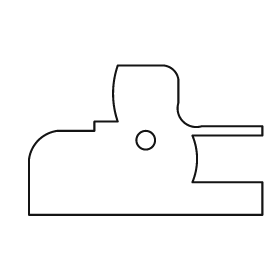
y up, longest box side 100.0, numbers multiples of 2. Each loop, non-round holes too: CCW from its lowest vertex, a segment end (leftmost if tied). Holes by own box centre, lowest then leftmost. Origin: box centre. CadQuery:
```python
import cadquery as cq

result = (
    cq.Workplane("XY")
    .moveTo(-50.0, -32.0)
    .lineTo(50.0, -32.0)
    .lineTo(50.0, -18.0)
    .lineTo(20.0, -18.0)
    .threePointArc((22.0, -8.0), (20.0, 2.0))
    .lineTo(50.0, 2.0)
    .lineTo(50.0, 6.0)
    .lineTo(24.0, 6.0)
    .threePointArc((16.0, 8.0), (14.0, 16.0))
    .lineTo(14.0, 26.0)
    .threePointArc((12.0, 30.0), (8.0, 32.0))
    .lineTo(-12.0, 32.0)
    .threePointArc((-14.0, 20.0), (-12.0, 8.0))
    .lineTo(-22.0, 8.0)
    .lineTo(-22.0, 4.0)
    .lineTo(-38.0, 4.0)
    .threePointArc((-46.0, 0.0), (-50.0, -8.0))
    .close()
    .moveTo(0.0, 0.0)
    .circle(4.0)
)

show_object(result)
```